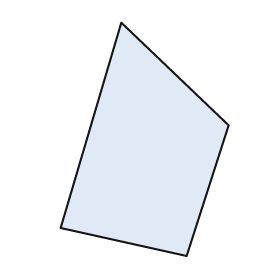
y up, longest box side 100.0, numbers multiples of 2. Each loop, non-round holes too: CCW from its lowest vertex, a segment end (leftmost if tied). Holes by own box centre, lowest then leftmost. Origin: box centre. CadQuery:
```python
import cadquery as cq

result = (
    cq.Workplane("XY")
    .moveTo(18.0, -50.0)
    .lineTo(36.0, 6.0)
    .lineTo(-10.0, 50.0)
    .lineTo(-36.0, -38.0)
    .close()
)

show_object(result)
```